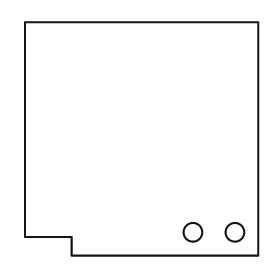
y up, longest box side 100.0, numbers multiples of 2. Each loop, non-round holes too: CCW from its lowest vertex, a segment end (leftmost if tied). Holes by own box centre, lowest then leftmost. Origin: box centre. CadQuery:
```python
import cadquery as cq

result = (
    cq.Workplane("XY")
    .moveTo(-30.0, -50.0)
    .lineTo(50.0, -50.0)
    .lineTo(50.0, 50.0)
    .lineTo(-50.0, 50.0)
    .lineTo(-50.0, -42.0)
    .lineTo(-30.0, -42.0)
    .close()
    .moveTo(22.0, -40.0)
    .circle(4.0)
    .moveTo(40.0, -40.0)
    .circle(4.0)
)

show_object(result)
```